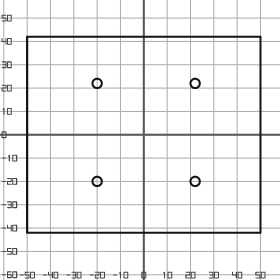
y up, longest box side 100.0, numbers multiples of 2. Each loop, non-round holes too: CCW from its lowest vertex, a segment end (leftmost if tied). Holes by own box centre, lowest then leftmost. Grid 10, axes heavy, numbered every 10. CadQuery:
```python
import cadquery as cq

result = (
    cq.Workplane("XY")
    .moveTo(-50.0, -42.0)
    .lineTo(50.0, -42.0)
    .lineTo(50.0, 42.0)
    .lineTo(-50.0, 42.0)
    .close()
    .moveTo(-20.0, -20.0)
    .circle(2.0)
    .moveTo(22.0, -20.0)
    .circle(2.0)
    .moveTo(-20.0, 22.0)
    .circle(2.0)
    .moveTo(22.0, 22.0)
    .circle(2.0)
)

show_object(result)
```